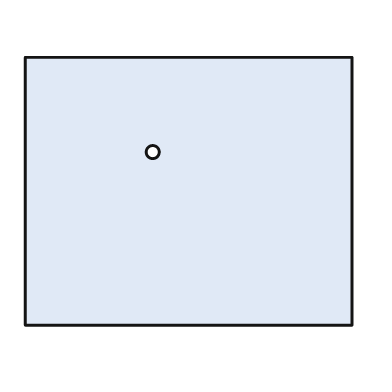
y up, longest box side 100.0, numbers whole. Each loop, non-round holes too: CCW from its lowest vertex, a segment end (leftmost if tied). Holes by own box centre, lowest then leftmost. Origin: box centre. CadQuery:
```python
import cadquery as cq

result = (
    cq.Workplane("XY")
    .moveTo(-50.0, -41.0)
    .lineTo(50.0, -41.0)
    .lineTo(50.0, 41.0)
    .lineTo(-50.0, 41.0)
    .close()
    .moveTo(-11.0, 12.0)
    .circle(2.0)
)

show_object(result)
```